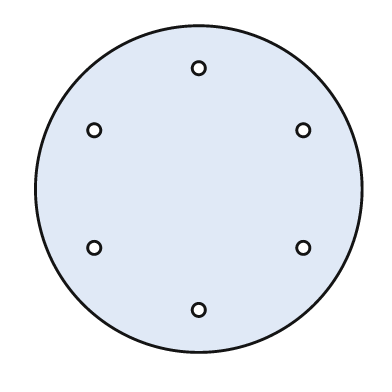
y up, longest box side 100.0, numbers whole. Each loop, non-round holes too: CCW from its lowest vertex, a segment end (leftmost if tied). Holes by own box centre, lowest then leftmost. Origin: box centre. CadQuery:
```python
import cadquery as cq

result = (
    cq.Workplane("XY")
    .moveTo(0.0, 0.0)
    .circle(50.0)
    .moveTo(0.0, -37.0)
    .circle(2.0)
    .moveTo(-32.0, -18.0)
    .circle(2.0)
    .moveTo(32.0, -18.0)
    .circle(2.0)
    .moveTo(-32.0, 18.0)
    .circle(2.0)
    .moveTo(32.0, 18.0)
    .circle(2.0)
    .moveTo(0.0, 37.0)
    .circle(2.0)
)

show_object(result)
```